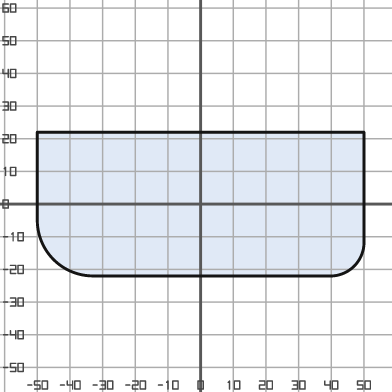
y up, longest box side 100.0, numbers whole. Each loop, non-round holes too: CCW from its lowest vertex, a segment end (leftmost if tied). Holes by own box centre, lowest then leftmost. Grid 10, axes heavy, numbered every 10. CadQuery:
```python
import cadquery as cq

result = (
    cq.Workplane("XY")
    .moveTo(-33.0, -22.0)
    .lineTo(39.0, -22.0)
    .threePointArc((47.0, -19.0), (50.0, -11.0))
    .lineTo(50.0, 22.0)
    .lineTo(-50.0, 22.0)
    .lineTo(-50.0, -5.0)
    .threePointArc((-45.0, -17.0), (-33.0, -22.0))
    .close()
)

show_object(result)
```